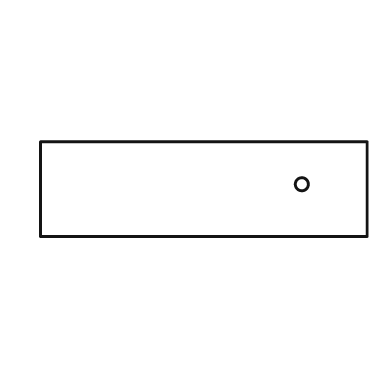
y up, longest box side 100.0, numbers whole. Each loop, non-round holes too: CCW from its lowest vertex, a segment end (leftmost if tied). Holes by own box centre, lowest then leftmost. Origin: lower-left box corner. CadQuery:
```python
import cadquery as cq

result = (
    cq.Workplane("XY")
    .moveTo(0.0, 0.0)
    .lineTo(100.0, 0.0)
    .lineTo(100.0, 29.0)
    .lineTo(0.0, 29.0)
    .close()
    .moveTo(80.0, 16.0)
    .circle(2.0)
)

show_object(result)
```